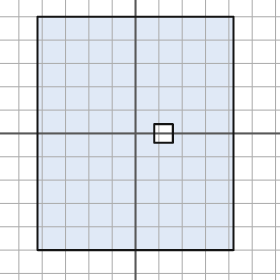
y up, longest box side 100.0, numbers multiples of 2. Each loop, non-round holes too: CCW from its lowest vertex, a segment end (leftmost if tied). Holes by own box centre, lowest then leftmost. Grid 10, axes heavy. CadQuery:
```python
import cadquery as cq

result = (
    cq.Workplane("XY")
    .moveTo(-42.0, -50.0)
    .lineTo(42.0, -50.0)
    .lineTo(42.0, 50.0)
    .lineTo(-42.0, 50.0)
    .close()
    .moveTo(8.0, -4.0)
    .lineTo(16.0, -4.0)
    .lineTo(16.0, 4.0)
    .lineTo(8.0, 4.0)
    .close()
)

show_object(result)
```